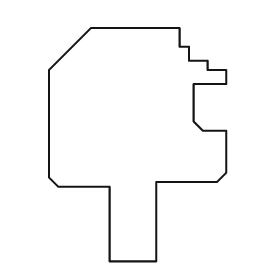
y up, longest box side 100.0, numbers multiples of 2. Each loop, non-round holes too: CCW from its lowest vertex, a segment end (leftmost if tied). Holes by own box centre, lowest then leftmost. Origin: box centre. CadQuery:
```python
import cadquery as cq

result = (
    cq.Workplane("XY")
    .moveTo(-12.0, -50.0)
    .lineTo(8.0, -50.0)
    .lineTo(8.0, -16.0)
    .lineTo(34.0, -16.0)
    .lineTo(38.0, -12.0)
    .lineTo(38.0, 6.0)
    .lineTo(28.0, 6.0)
    .lineTo(24.0, 10.0)
    .lineTo(24.0, 26.0)
    .lineTo(38.0, 26.0)
    .lineTo(38.0, 32.0)
    .lineTo(30.0, 32.0)
    .lineTo(30.0, 36.0)
    .lineTo(22.0, 36.0)
    .lineTo(22.0, 42.0)
    .lineTo(18.0, 42.0)
    .lineTo(18.0, 50.0)
    .lineTo(-20.0, 50.0)
    .lineTo(-38.0, 32.0)
    .lineTo(-38.0, -14.0)
    .lineTo(-34.0, -18.0)
    .lineTo(-12.0, -18.0)
    .close()
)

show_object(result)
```